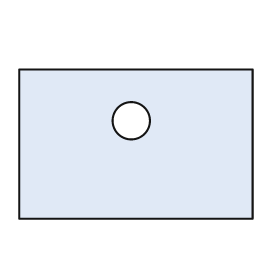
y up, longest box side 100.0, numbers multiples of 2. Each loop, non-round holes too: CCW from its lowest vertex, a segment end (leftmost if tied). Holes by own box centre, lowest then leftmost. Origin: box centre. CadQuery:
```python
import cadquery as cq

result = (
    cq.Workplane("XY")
    .moveTo(-50.0, -32.0)
    .lineTo(50.0, -32.0)
    .lineTo(50.0, 32.0)
    .lineTo(-50.0, 32.0)
    .close()
    .moveTo(-2.0, 10.0)
    .circle(8.0)
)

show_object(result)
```